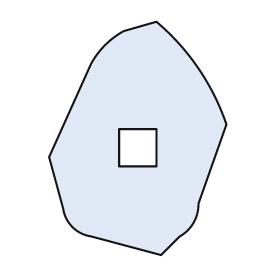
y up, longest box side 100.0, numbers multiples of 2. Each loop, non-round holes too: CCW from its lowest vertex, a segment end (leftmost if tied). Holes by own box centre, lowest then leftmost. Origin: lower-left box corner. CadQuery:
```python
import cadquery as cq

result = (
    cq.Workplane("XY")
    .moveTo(48.0, 0.0)
    .lineTo(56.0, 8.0)
    .threePointArc((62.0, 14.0), (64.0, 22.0))
    .lineTo(76.0, 56.0)
    .threePointArc((64.0, 80.0), (46.0, 100.0))
    .lineTo(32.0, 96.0)
    .threePointArc((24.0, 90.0), (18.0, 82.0))
    .lineTo(0.0, 42.0)
    .lineTo(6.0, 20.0)
    .threePointArc((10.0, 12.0), (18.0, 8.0))
    .close()
    .moveTo(30.0, 38.0)
    .lineTo(46.0, 38.0)
    .lineTo(46.0, 54.0)
    .lineTo(30.0, 54.0)
    .close()
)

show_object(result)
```